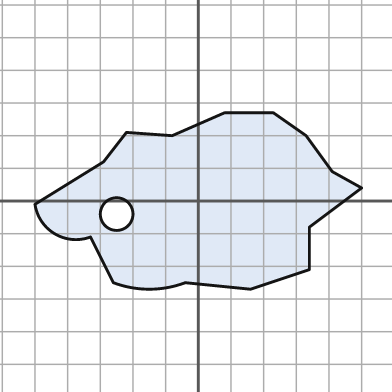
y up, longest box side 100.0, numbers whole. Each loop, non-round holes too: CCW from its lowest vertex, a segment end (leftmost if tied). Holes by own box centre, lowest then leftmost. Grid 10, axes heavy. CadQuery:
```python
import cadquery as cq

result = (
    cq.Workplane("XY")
    .moveTo(16.0, -27.0)
    .lineTo(34.0, -21.0)
    .lineTo(34.0, -8.0)
    .lineTo(50.0, 4.0)
    .lineTo(41.0, 9.0)
    .lineTo(33.0, 20.0)
    .lineTo(23.0, 27.0)
    .lineTo(8.0, 27.0)
    .lineTo(-8.0, 20.0)
    .lineTo(-22.0, 21.0)
    .lineTo(-29.0, 12.0)
    .lineTo(-50.0, -1.0)
    .threePointArc((-44.0, -10.0), (-33.0, -11.0))
    .lineTo(-26.0, -25.0)
    .threePointArc((-15.0, -27.0), (-4.0, -25.0))
    .close()
    .moveTo(-25.0, -4.0)
    .circle(5.0)
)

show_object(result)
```